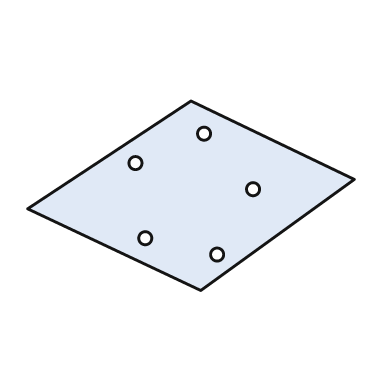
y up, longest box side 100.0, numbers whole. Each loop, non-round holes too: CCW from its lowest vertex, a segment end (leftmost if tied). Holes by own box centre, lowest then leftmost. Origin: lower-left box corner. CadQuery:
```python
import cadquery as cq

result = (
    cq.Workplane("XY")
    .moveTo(53.0, 0.0)
    .lineTo(100.0, 34.0)
    .lineTo(50.0, 58.0)
    .lineTo(0.0, 25.0)
    .close()
    .moveTo(58.0, 11.0)
    .circle(2.0)
    .moveTo(36.0, 16.0)
    .circle(2.0)
    .moveTo(69.0, 31.0)
    .circle(2.0)
    .moveTo(33.0, 39.0)
    .circle(2.0)
    .moveTo(54.0, 48.0)
    .circle(2.0)
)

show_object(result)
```